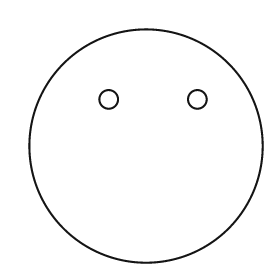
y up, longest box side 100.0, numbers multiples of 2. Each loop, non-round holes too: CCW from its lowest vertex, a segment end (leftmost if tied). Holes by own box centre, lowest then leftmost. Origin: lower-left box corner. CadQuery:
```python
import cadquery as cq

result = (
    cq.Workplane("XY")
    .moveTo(50.0, 50.0)
    .circle(50.0)
    .moveTo(34.0, 70.0)
    .circle(4.0)
    .moveTo(72.0, 70.0)
    .circle(4.0)
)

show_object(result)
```